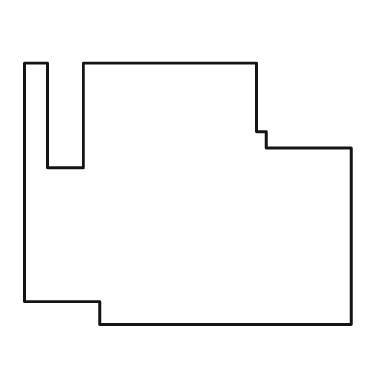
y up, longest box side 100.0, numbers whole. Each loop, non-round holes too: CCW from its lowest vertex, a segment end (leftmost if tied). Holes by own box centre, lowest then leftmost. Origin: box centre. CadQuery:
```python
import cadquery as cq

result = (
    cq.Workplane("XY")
    .moveTo(-27.0, -40.0)
    .lineTo(50.0, -40.0)
    .lineTo(50.0, 14.0)
    .lineTo(24.0, 14.0)
    .lineTo(24.0, 19.0)
    .lineTo(21.0, 19.0)
    .lineTo(21.0, 40.0)
    .lineTo(-32.0, 40.0)
    .lineTo(-32.0, 8.0)
    .lineTo(-43.0, 8.0)
    .lineTo(-43.0, 40.0)
    .lineTo(-50.0, 40.0)
    .lineTo(-50.0, -33.0)
    .lineTo(-27.0, -33.0)
    .close()
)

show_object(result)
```